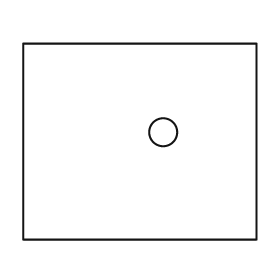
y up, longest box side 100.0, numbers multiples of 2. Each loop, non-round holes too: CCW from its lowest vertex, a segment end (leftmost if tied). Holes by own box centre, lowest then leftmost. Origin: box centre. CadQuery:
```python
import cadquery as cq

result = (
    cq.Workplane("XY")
    .moveTo(-50.0, -42.0)
    .lineTo(50.0, -42.0)
    .lineTo(50.0, 42.0)
    .lineTo(-50.0, 42.0)
    .close()
    .moveTo(10.0, 4.0)
    .circle(6.0)
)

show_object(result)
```